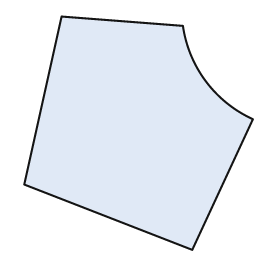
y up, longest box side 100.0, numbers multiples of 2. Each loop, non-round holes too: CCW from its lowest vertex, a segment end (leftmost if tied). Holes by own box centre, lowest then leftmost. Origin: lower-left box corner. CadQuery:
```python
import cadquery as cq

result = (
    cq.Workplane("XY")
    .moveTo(72.0, 0.0)
    .lineTo(98.0, 56.0)
    .threePointArc((78.0, 72.0), (68.0, 96.0))
    .lineTo(16.0, 100.0)
    .lineTo(0.0, 28.0)
    .close()
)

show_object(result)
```